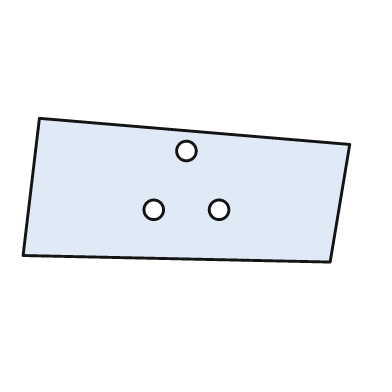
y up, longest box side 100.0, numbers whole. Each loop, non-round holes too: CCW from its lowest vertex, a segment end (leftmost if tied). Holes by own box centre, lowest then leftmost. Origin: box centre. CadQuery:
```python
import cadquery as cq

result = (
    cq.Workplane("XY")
    .moveTo(44.0, -22.0)
    .lineTo(50.0, 14.0)
    .lineTo(-45.0, 22.0)
    .lineTo(-50.0, -20.0)
    .close()
    .moveTo(-10.0, -6.0)
    .circle(3.0)
    .moveTo(10.0, -6.0)
    .circle(3.0)
    .moveTo(0.0, 12.0)
    .circle(3.0)
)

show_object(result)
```